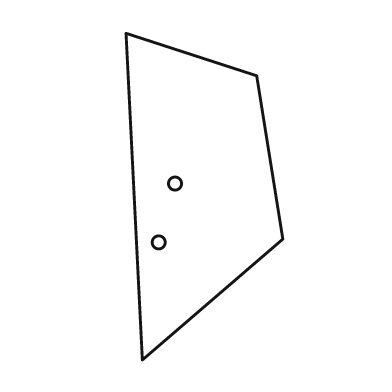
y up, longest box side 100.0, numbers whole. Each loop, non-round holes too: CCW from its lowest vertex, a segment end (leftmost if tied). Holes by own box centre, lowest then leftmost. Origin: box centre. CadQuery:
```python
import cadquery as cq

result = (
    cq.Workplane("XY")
    .moveTo(-19.0, -50.0)
    .lineTo(24.0, -13.0)
    .lineTo(16.0, 37.0)
    .lineTo(-24.0, 50.0)
    .close()
    .moveTo(-14.0, -14.0)
    .circle(2.0)
    .moveTo(-9.0, 4.0)
    .circle(2.0)
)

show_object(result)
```